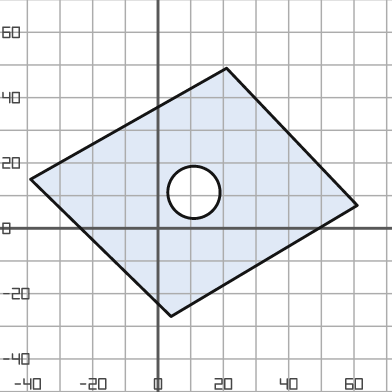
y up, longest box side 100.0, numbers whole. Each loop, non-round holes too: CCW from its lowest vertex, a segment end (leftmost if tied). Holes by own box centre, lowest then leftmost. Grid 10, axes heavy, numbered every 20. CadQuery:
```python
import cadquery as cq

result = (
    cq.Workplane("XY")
    .moveTo(4.0, -27.0)
    .lineTo(61.0, 7.0)
    .lineTo(21.0, 49.0)
    .lineTo(-39.0, 15.0)
    .close()
    .moveTo(11.0, 11.0)
    .circle(8.0)
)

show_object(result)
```